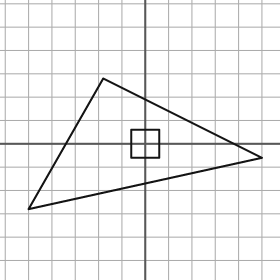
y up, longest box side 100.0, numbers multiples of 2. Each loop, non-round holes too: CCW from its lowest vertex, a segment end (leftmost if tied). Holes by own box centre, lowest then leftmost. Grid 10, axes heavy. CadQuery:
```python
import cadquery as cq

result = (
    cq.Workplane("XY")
    .moveTo(-50.0, -28.0)
    .lineTo(50.0, -6.0)
    .lineTo(-18.0, 28.0)
    .close()
    .moveTo(-6.0, -6.0)
    .lineTo(6.0, -6.0)
    .lineTo(6.0, 6.0)
    .lineTo(-6.0, 6.0)
    .close()
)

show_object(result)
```